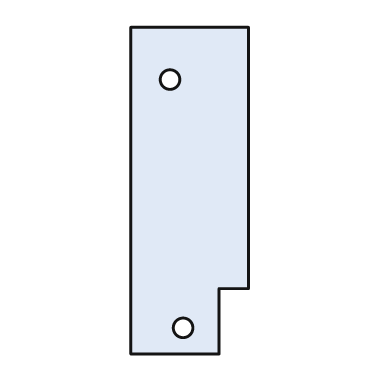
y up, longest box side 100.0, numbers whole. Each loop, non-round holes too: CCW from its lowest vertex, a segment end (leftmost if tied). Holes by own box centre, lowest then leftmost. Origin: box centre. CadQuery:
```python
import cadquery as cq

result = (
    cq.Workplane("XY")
    .moveTo(-18.0, -50.0)
    .lineTo(9.0, -50.0)
    .lineTo(9.0, -30.0)
    .lineTo(18.0, -30.0)
    .lineTo(18.0, 50.0)
    .lineTo(-18.0, 50.0)
    .close()
    .moveTo(-2.0, -42.0)
    .circle(3.0)
    .moveTo(-6.0, 34.0)
    .circle(3.0)
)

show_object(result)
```